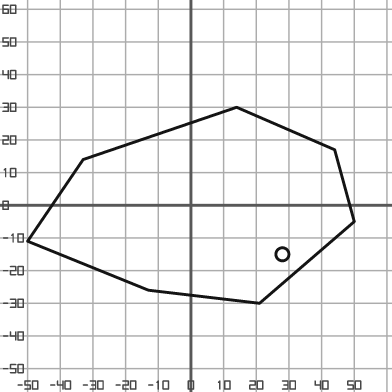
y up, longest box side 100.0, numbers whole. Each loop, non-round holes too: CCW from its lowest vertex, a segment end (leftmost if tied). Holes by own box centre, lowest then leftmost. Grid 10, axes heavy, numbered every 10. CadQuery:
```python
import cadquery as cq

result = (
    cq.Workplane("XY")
    .moveTo(21.0, -30.0)
    .lineTo(50.0, -5.0)
    .lineTo(44.0, 17.0)
    .lineTo(14.0, 30.0)
    .lineTo(-33.0, 14.0)
    .lineTo(-50.0, -11.0)
    .lineTo(-13.0, -26.0)
    .close()
    .moveTo(28.0, -15.0)
    .circle(2.0)
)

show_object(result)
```